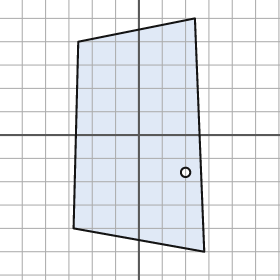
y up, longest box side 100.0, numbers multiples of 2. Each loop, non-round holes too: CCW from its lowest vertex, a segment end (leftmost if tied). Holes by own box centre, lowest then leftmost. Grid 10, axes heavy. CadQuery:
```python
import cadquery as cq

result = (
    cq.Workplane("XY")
    .moveTo(28.0, -50.0)
    .lineTo(24.0, 50.0)
    .lineTo(-26.0, 40.0)
    .lineTo(-28.0, -40.0)
    .close()
    .moveTo(20.0, -16.0)
    .circle(2.0)
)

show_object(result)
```